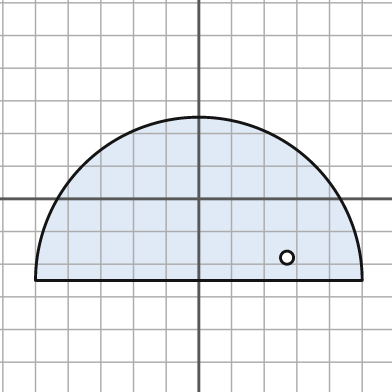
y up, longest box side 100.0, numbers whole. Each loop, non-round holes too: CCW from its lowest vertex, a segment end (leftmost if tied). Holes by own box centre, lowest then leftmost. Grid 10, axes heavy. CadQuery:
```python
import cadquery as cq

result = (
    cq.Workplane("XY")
    .moveTo(-50.0, -25.0)
    .lineTo(50.0, -25.0)
    .threePointArc((0.0, 25.0), (-50.0, -25.0))
    .close()
    .moveTo(27.0, -18.0)
    .circle(2.0)
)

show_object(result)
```